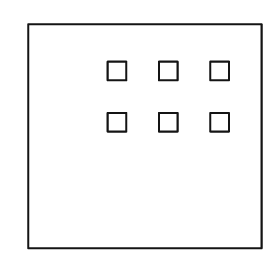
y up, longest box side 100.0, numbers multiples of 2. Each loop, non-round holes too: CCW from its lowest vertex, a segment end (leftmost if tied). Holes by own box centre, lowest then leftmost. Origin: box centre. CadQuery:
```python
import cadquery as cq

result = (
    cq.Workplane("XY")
    .moveTo(-50.0, -48.0)
    .lineTo(50.0, -48.0)
    .lineTo(50.0, 48.0)
    .lineTo(-50.0, 48.0)
    .close()
    .moveTo(-16.0, 2.0)
    .lineTo(-8.0, 2.0)
    .lineTo(-8.0, 10.0)
    .lineTo(-16.0, 10.0)
    .close()
    .moveTo(6.0, 2.0)
    .lineTo(14.0, 2.0)
    .lineTo(14.0, 10.0)
    .lineTo(6.0, 10.0)
    .close()
    .moveTo(28.0, 2.0)
    .lineTo(36.0, 2.0)
    .lineTo(36.0, 10.0)
    .lineTo(28.0, 10.0)
    .close()
    .moveTo(-16.0, 24.0)
    .lineTo(-8.0, 24.0)
    .lineTo(-8.0, 32.0)
    .lineTo(-16.0, 32.0)
    .close()
    .moveTo(6.0, 24.0)
    .lineTo(14.0, 24.0)
    .lineTo(14.0, 32.0)
    .lineTo(6.0, 32.0)
    .close()
    .moveTo(28.0, 24.0)
    .lineTo(36.0, 24.0)
    .lineTo(36.0, 32.0)
    .lineTo(28.0, 32.0)
    .close()
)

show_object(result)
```